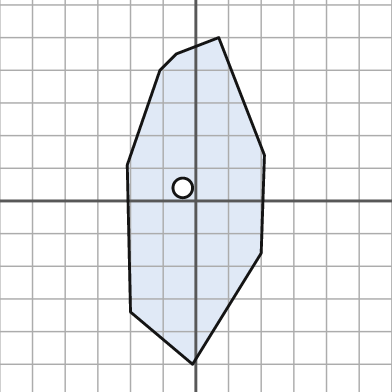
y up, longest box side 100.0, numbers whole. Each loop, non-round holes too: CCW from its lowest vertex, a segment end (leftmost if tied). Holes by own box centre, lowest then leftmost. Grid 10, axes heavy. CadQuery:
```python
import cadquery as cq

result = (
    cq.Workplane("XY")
    .moveTo(-1.0, -50.0)
    .lineTo(20.0, -16.0)
    .lineTo(21.0, 14.0)
    .lineTo(7.0, 50.0)
    .lineTo(-6.0, 45.0)
    .lineTo(-11.0, 40.0)
    .lineTo(-21.0, 11.0)
    .lineTo(-20.0, -34.0)
    .close()
    .moveTo(-4.0, 4.0)
    .circle(3.0)
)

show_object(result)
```